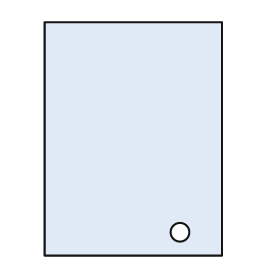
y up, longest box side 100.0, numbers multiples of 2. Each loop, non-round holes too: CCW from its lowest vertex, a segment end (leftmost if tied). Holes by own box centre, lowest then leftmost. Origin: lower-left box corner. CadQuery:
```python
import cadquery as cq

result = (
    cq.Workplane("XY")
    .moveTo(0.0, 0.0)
    .lineTo(76.0, 0.0)
    .lineTo(76.0, 100.0)
    .lineTo(0.0, 100.0)
    .close()
    .moveTo(58.0, 10.0)
    .circle(4.0)
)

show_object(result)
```